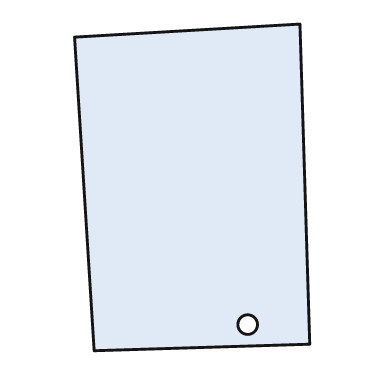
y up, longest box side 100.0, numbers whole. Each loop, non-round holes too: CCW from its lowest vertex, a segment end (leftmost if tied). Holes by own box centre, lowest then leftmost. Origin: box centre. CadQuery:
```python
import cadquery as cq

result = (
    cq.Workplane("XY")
    .moveTo(-30.0, -50.0)
    .lineTo(36.0, -48.0)
    .lineTo(33.0, 50.0)
    .lineTo(-36.0, 46.0)
    .close()
    .moveTo(17.0, -42.0)
    .circle(3.0)
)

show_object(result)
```